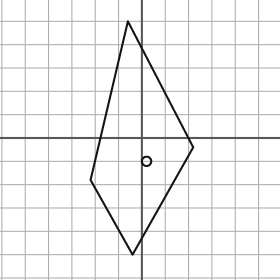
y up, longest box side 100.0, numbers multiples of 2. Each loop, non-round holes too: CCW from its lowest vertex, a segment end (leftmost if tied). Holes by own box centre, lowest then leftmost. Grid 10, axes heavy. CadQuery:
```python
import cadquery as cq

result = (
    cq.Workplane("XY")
    .moveTo(-4.0, -50.0)
    .lineTo(22.0, -4.0)
    .lineTo(-6.0, 50.0)
    .lineTo(-22.0, -18.0)
    .close()
    .moveTo(2.0, -10.0)
    .circle(2.0)
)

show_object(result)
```